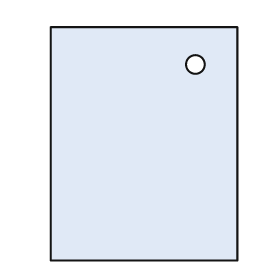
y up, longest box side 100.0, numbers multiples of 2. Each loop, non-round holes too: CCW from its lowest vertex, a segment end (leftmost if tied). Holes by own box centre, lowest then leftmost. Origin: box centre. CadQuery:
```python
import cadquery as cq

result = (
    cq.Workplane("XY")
    .moveTo(-40.0, -50.0)
    .lineTo(40.0, -50.0)
    .lineTo(40.0, 50.0)
    .lineTo(-40.0, 50.0)
    .close()
    .moveTo(22.0, 34.0)
    .circle(4.0)
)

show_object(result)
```